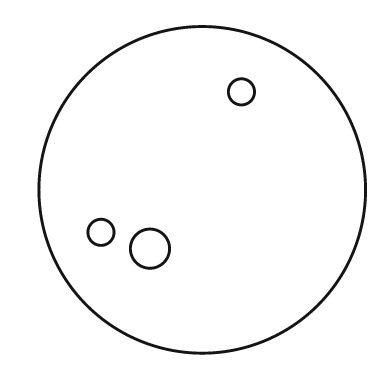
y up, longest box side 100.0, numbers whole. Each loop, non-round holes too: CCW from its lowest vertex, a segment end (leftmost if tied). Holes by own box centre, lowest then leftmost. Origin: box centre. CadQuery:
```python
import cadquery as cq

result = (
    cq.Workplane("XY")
    .moveTo(0.0, 0.0)
    .circle(50.0)
    .moveTo(-16.0, -18.0)
    .circle(6.0)
    .moveTo(-31.0, -13.0)
    .circle(4.0)
    .moveTo(12.0, 30.0)
    .circle(4.0)
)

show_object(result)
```